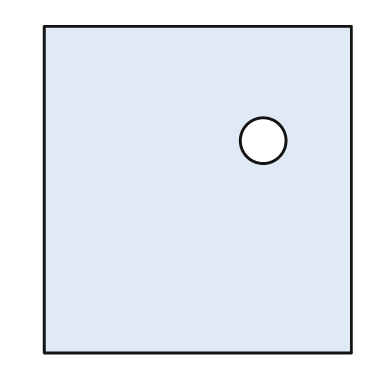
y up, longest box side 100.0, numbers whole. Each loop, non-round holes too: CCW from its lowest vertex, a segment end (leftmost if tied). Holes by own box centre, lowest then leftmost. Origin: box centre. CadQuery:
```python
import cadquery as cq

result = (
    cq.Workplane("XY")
    .moveTo(-47.0, -50.0)
    .lineTo(47.0, -50.0)
    .lineTo(47.0, 50.0)
    .lineTo(-47.0, 50.0)
    .close()
    .moveTo(20.0, 15.0)
    .circle(7.0)
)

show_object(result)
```